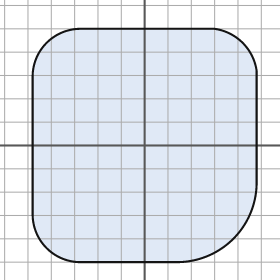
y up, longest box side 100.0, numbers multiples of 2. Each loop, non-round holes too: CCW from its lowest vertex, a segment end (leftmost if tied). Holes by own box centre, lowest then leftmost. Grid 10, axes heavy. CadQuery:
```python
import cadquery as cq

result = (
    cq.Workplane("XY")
    .moveTo(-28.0, -50.0)
    .lineTo(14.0, -50.0)
    .threePointArc((38.0, -40.0), (48.0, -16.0))
    .lineTo(48.0, 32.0)
    .threePointArc((42.0, 44.0), (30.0, 50.0))
    .lineTo(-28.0, 50.0)
    .threePointArc((-42.0, 44.0), (-48.0, 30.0))
    .lineTo(-48.0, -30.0)
    .threePointArc((-42.0, -44.0), (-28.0, -50.0))
    .close()
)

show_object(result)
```